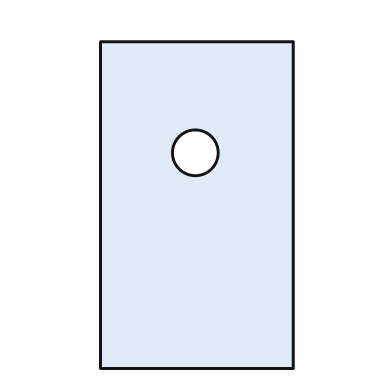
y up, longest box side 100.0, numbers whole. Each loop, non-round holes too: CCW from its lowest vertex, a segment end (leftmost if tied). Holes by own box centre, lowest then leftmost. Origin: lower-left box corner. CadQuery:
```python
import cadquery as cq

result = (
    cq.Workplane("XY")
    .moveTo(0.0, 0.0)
    .lineTo(59.0, 0.0)
    .lineTo(59.0, 100.0)
    .lineTo(0.0, 100.0)
    .close()
    .moveTo(29.0, 66.0)
    .circle(7.0)
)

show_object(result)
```